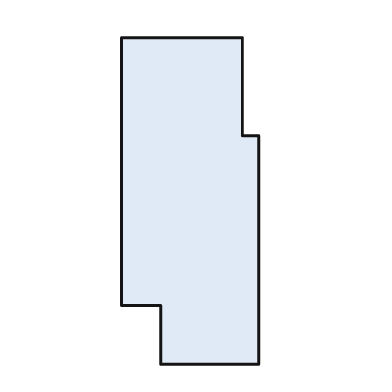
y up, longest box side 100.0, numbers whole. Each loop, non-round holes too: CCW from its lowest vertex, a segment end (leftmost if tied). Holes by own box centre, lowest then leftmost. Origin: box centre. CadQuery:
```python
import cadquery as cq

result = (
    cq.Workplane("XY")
    .moveTo(-9.0, -50.0)
    .lineTo(21.0, -50.0)
    .lineTo(21.0, 20.0)
    .lineTo(16.0, 20.0)
    .lineTo(16.0, 50.0)
    .lineTo(-21.0, 50.0)
    .lineTo(-21.0, -32.0)
    .lineTo(-9.0, -32.0)
    .close()
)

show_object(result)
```